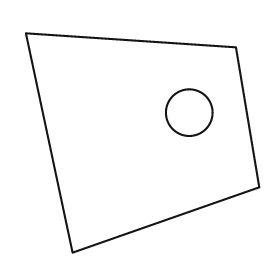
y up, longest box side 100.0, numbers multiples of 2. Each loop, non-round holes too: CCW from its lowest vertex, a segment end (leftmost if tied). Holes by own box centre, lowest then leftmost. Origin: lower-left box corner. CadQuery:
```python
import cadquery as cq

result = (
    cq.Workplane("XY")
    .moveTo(20.0, 0.0)
    .lineTo(100.0, 28.0)
    .lineTo(90.0, 88.0)
    .lineTo(0.0, 94.0)
    .close()
    .moveTo(70.0, 60.0)
    .circle(10.0)
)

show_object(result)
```